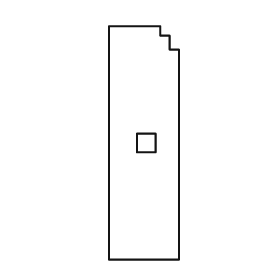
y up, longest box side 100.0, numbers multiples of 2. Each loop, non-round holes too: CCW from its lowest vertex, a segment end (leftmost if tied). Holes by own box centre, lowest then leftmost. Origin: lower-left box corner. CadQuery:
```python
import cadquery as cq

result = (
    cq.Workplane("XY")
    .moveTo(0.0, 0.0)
    .lineTo(30.0, 0.0)
    .lineTo(30.0, 90.0)
    .lineTo(26.0, 90.0)
    .lineTo(26.0, 96.0)
    .lineTo(22.0, 96.0)
    .lineTo(22.0, 100.0)
    .lineTo(0.0, 100.0)
    .close()
    .moveTo(12.0, 46.0)
    .lineTo(20.0, 46.0)
    .lineTo(20.0, 54.0)
    .lineTo(12.0, 54.0)
    .close()
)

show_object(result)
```